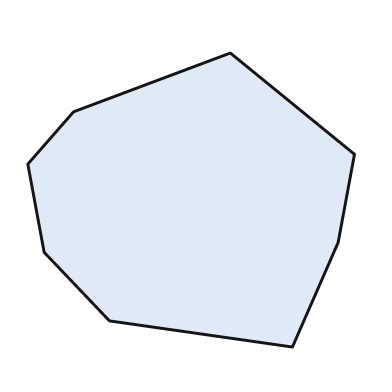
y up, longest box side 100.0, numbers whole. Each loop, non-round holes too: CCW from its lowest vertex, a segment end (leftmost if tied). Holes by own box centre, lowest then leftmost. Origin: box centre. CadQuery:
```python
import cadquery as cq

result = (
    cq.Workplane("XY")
    .moveTo(31.0, -45.0)
    .lineTo(45.0, -13.0)
    .lineTo(50.0, 14.0)
    .lineTo(12.0, 45.0)
    .lineTo(-36.0, 27.0)
    .lineTo(-50.0, 11.0)
    .lineTo(-45.0, -16.0)
    .lineTo(-25.0, -37.0)
    .close()
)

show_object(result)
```